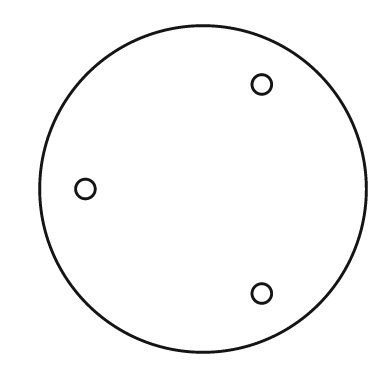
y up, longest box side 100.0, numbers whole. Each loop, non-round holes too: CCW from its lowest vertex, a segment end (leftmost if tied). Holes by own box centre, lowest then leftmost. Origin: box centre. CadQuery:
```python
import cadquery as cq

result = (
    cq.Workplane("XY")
    .moveTo(0.0, 0.0)
    .circle(50.0)
    .moveTo(18.0, -32.0)
    .circle(3.0)
    .moveTo(-36.0, 0.0)
    .circle(3.0)
    .moveTo(18.0, 32.0)
    .circle(3.0)
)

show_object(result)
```